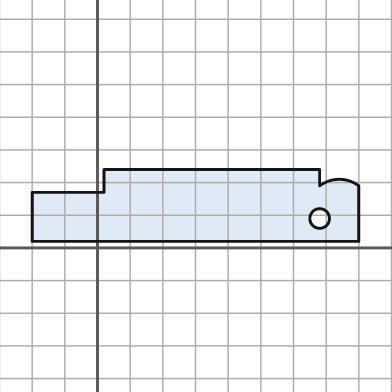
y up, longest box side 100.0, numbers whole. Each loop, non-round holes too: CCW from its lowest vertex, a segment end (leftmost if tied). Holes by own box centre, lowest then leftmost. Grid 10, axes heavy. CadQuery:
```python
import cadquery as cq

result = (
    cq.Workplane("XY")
    .moveTo(-20.0, 2.0)
    .lineTo(80.0, 2.0)
    .lineTo(80.0, 19.0)
    .threePointArc((74.0, 21.0), (68.0, 19.0))
    .lineTo(68.0, 24.0)
    .lineTo(2.0, 24.0)
    .lineTo(2.0, 17.0)
    .lineTo(-20.0, 17.0)
    .close()
    .moveTo(68.0, 9.0)
    .circle(3.0)
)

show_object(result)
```